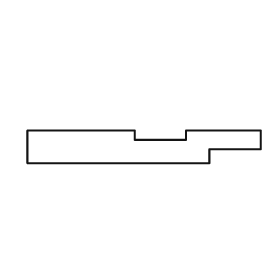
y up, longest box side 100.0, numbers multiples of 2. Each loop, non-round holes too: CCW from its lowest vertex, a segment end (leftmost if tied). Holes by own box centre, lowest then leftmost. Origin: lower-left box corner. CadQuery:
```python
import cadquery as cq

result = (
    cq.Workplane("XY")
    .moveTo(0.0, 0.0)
    .lineTo(78.0, 0.0)
    .lineTo(78.0, 6.0)
    .lineTo(100.0, 6.0)
    .lineTo(100.0, 14.0)
    .lineTo(68.0, 14.0)
    .lineTo(68.0, 10.0)
    .lineTo(46.0, 10.0)
    .lineTo(46.0, 14.0)
    .lineTo(0.0, 14.0)
    .close()
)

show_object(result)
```